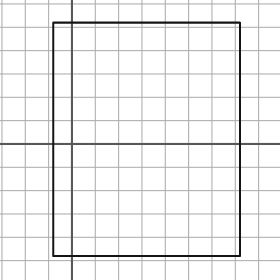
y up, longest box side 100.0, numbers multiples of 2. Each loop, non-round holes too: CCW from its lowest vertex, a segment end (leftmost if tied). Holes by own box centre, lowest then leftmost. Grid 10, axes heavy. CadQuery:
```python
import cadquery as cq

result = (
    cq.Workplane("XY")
    .moveTo(-8.0, -48.0)
    .lineTo(72.0, -48.0)
    .lineTo(72.0, 52.0)
    .lineTo(-8.0, 52.0)
    .close()
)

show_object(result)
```